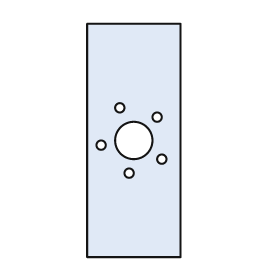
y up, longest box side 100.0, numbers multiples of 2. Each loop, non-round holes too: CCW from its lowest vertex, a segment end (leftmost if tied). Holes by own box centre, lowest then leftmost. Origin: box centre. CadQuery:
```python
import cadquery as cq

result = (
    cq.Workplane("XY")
    .moveTo(-20.0, -50.0)
    .lineTo(20.0, -50.0)
    .lineTo(20.0, 50.0)
    .lineTo(-20.0, 50.0)
    .close()
    .moveTo(-2.0, -14.0)
    .circle(2.0)
    .moveTo(12.0, -8.0)
    .circle(2.0)
    .moveTo(-14.0, -2.0)
    .circle(2.0)
    .moveTo(0.0, 0.0)
    .circle(8.0)
    .moveTo(10.0, 10.0)
    .circle(2.0)
    .moveTo(-6.0, 14.0)
    .circle(2.0)
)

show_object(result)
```